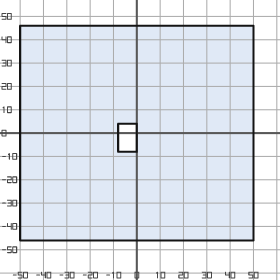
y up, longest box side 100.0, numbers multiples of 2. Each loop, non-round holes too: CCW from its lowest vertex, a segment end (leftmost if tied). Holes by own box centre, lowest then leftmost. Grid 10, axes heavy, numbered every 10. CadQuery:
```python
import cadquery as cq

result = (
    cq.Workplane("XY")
    .moveTo(-50.0, -46.0)
    .lineTo(50.0, -46.0)
    .lineTo(50.0, 46.0)
    .lineTo(-50.0, 46.0)
    .close()
    .moveTo(-8.0, -8.0)
    .lineTo(0.0, -8.0)
    .lineTo(0.0, 4.0)
    .lineTo(-8.0, 4.0)
    .close()
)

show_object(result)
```